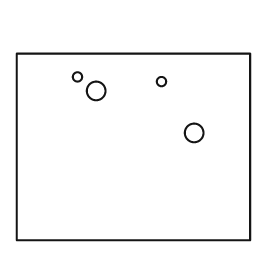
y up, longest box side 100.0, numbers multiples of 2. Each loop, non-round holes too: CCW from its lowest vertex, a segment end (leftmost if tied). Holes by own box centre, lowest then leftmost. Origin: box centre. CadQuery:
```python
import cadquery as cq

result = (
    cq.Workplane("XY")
    .moveTo(-50.0, -40.0)
    .lineTo(50.0, -40.0)
    .lineTo(50.0, 40.0)
    .lineTo(-50.0, 40.0)
    .close()
    .moveTo(26.0, 6.0)
    .circle(4.0)
    .moveTo(-16.0, 24.0)
    .circle(4.0)
    .moveTo(12.0, 28.0)
    .circle(2.0)
    .moveTo(-24.0, 30.0)
    .circle(2.0)
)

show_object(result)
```